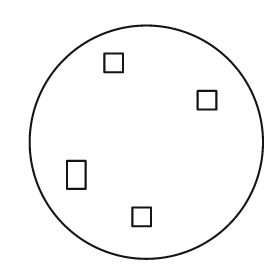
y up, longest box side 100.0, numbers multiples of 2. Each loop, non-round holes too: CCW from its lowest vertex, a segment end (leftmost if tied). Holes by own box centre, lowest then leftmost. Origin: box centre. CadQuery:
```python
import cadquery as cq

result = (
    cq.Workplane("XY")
    .moveTo(0.0, 0.0)
    .circle(50.0)
    .moveTo(-6.0, -36.0)
    .lineTo(2.0, -36.0)
    .lineTo(2.0, -28.0)
    .lineTo(-6.0, -28.0)
    .close()
    .moveTo(-34.0, -20.0)
    .lineTo(-26.0, -20.0)
    .lineTo(-26.0, -8.0)
    .lineTo(-34.0, -8.0)
    .close()
    .moveTo(22.0, 14.0)
    .lineTo(30.0, 14.0)
    .lineTo(30.0, 22.0)
    .lineTo(22.0, 22.0)
    .close()
    .moveTo(-18.0, 30.0)
    .lineTo(-10.0, 30.0)
    .lineTo(-10.0, 38.0)
    .lineTo(-18.0, 38.0)
    .close()
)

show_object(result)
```